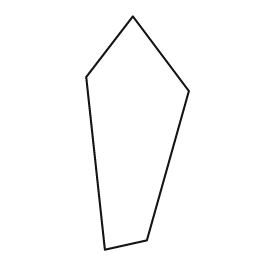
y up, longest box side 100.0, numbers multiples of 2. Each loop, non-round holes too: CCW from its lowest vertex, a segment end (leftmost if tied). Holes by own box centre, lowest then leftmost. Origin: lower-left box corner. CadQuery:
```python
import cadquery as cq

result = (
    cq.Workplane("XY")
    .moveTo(8.0, 0.0)
    .lineTo(26.0, 4.0)
    .lineTo(44.0, 68.0)
    .lineTo(20.0, 100.0)
    .lineTo(0.0, 74.0)
    .close()
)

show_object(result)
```